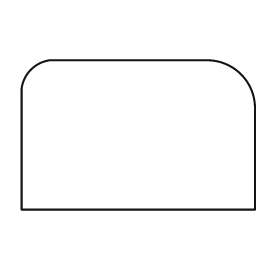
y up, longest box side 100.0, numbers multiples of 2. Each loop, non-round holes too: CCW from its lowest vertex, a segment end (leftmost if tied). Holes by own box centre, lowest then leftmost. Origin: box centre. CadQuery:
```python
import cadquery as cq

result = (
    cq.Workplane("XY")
    .moveTo(-50.0, -32.0)
    .lineTo(50.0, -32.0)
    .lineTo(50.0, 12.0)
    .threePointArc((44.0, 26.0), (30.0, 32.0))
    .lineTo(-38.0, 32.0)
    .threePointArc((-46.0, 28.0), (-50.0, 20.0))
    .close()
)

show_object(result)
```